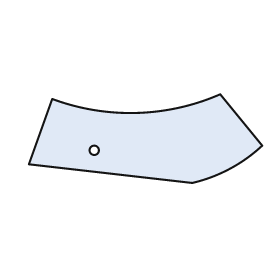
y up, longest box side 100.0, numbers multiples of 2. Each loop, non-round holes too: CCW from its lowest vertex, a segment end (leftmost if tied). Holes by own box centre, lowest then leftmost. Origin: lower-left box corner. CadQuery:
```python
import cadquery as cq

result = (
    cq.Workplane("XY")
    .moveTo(70.0, 0.0)
    .threePointArc((86.0, 6.0), (100.0, 16.0))
    .lineTo(82.0, 38.0)
    .threePointArc((46.0, 30.0), (10.0, 36.0))
    .lineTo(0.0, 8.0)
    .close()
    .moveTo(28.0, 14.0)
    .circle(2.0)
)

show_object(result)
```